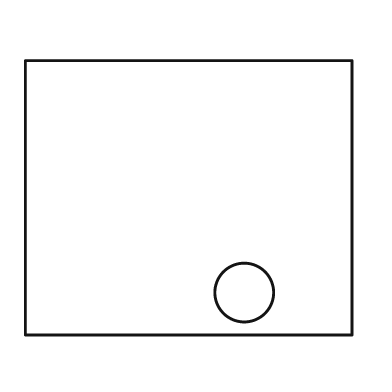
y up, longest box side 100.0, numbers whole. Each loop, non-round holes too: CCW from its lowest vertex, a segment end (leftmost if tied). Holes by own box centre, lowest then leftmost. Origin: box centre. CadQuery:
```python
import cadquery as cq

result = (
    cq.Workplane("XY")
    .moveTo(-50.0, -42.0)
    .lineTo(50.0, -42.0)
    .lineTo(50.0, 42.0)
    .lineTo(-50.0, 42.0)
    .close()
    .moveTo(17.0, -29.0)
    .circle(9.0)
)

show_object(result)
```